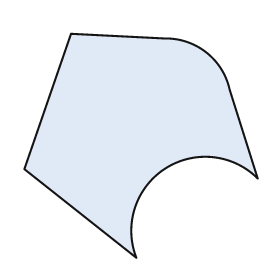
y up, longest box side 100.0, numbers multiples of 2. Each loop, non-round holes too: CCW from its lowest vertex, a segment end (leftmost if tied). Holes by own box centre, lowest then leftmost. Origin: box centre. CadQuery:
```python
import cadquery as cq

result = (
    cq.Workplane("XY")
    .moveTo(-2.0, -48.0)
    .threePointArc((10.0, -10.0), (50.0, -14.0))
    .lineTo(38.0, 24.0)
    .threePointArc((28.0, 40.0), (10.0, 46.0))
    .lineTo(-30.0, 48.0)
    .lineTo(-50.0, -10.0)
    .close()
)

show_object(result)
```